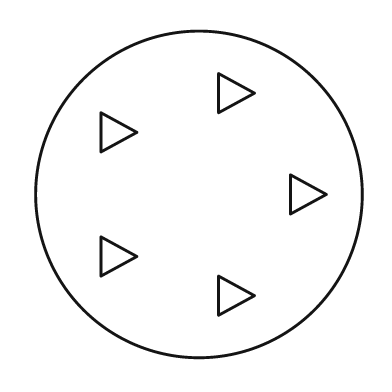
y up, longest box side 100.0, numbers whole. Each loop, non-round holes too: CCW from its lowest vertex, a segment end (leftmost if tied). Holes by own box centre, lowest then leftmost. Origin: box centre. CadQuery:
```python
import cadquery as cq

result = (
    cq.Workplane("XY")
    .moveTo(0.0, 0.0)
    .circle(50.0)
    .moveTo(6.0, -37.0)
    .lineTo(17.0, -31.0)
    .lineTo(6.0, -25.0)
    .close()
    .moveTo(-30.0, -25.0)
    .lineTo(-19.0, -19.0)
    .lineTo(-30.0, -13.0)
    .close()
    .moveTo(28.0, -6.0)
    .lineTo(39.0, 0.0)
    .lineTo(28.0, 6.0)
    .close()
    .moveTo(-30.0, 13.0)
    .lineTo(-19.0, 19.0)
    .lineTo(-30.0, 25.0)
    .close()
    .moveTo(6.0, 25.0)
    .lineTo(17.0, 31.0)
    .lineTo(6.0, 37.0)
    .close()
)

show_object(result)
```